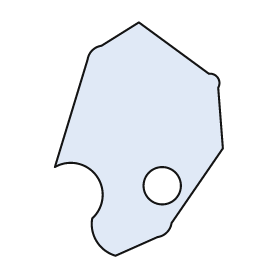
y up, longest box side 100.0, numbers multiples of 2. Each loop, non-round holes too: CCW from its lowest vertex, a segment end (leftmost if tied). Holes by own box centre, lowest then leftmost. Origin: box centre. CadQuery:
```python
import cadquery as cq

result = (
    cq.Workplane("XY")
    .moveTo(-10.0, -50.0)
    .lineTo(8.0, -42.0)
    .threePointArc((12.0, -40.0), (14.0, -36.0))
    .lineTo(36.0, -4.0)
    .lineTo(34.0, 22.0)
    .threePointArc((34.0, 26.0), (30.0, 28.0))
    .lineTo(0.0, 50.0)
    .lineTo(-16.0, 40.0)
    .threePointArc((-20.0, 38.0), (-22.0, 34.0))
    .lineTo(-36.0, -12.0)
    .threePointArc((-18.0, -16.0), (-20.0, -34.0))
    .threePointArc((-18.0, -44.0), (-10.0, -50.0))
    .close()
    .moveTo(10.0, -20.0)
    .circle(8.0)
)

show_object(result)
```